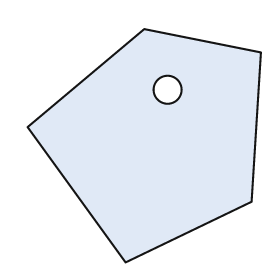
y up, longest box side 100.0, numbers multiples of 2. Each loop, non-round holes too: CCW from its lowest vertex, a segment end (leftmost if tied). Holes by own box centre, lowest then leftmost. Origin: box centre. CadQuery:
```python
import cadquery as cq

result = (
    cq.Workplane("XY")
    .moveTo(-8.0, -50.0)
    .lineTo(46.0, -24.0)
    .lineTo(50.0, 40.0)
    .lineTo(0.0, 50.0)
    .lineTo(-50.0, 8.0)
    .close()
    .moveTo(10.0, 24.0)
    .circle(6.0)
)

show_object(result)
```